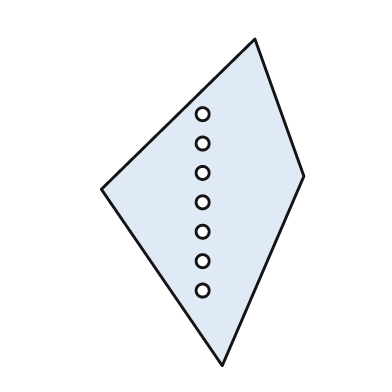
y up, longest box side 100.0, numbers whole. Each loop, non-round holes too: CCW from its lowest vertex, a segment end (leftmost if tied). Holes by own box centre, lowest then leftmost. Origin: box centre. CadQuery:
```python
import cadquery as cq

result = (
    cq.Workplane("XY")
    .moveTo(6.0, -50.0)
    .lineTo(31.0, 8.0)
    .lineTo(16.0, 50.0)
    .lineTo(-31.0, 4.0)
    .close()
    .moveTo(0.0, -27.0)
    .circle(2.0)
    .moveTo(0.0, -18.0)
    .circle(2.0)
    .moveTo(0.0, -9.0)
    .circle(2.0)
    .moveTo(0.0, 0.0)
    .circle(2.0)
    .moveTo(0.0, 9.0)
    .circle(2.0)
    .moveTo(0.0, 18.0)
    .circle(2.0)
    .moveTo(0.0, 27.0)
    .circle(2.0)
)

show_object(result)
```